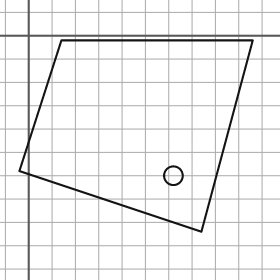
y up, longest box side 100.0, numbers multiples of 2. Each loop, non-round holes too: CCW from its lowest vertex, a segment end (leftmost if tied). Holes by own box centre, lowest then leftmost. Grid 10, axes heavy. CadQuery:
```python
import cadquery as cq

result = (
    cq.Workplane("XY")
    .moveTo(74.0, -84.0)
    .lineTo(96.0, -2.0)
    .lineTo(14.0, -2.0)
    .lineTo(-4.0, -58.0)
    .close()
    .moveTo(62.0, -60.0)
    .circle(4.0)
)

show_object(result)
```